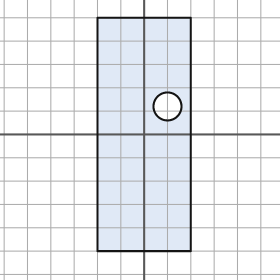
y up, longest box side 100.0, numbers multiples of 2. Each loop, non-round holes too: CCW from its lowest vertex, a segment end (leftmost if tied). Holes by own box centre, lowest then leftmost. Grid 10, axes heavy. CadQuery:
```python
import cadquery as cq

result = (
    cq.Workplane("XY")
    .moveTo(-20.0, -50.0)
    .lineTo(20.0, -50.0)
    .lineTo(20.0, 50.0)
    .lineTo(-20.0, 50.0)
    .close()
    .moveTo(10.0, 12.0)
    .circle(6.0)
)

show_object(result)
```